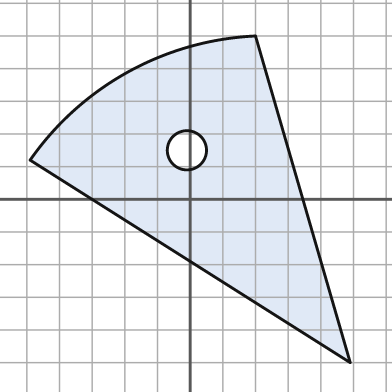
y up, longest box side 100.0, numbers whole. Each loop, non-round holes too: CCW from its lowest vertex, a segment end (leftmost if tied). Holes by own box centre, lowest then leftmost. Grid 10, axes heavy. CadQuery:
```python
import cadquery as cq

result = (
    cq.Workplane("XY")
    .moveTo(49.0, -50.0)
    .lineTo(20.0, 50.0)
    .threePointArc((-19.0, 39.0), (-49.0, 12.0))
    .close()
    .moveTo(-1.0, 15.0)
    .circle(6.0)
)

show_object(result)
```